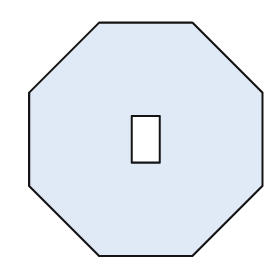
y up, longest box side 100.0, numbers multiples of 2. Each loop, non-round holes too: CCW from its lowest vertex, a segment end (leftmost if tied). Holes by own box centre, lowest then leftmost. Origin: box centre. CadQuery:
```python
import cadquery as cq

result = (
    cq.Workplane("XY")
    .moveTo(-20.0, -50.0)
    .lineTo(20.0, -50.0)
    .lineTo(50.0, -20.0)
    .lineTo(50.0, 20.0)
    .lineTo(20.0, 50.0)
    .lineTo(-20.0, 50.0)
    .lineTo(-50.0, 20.0)
    .lineTo(-50.0, -20.0)
    .close()
    .moveTo(-6.0, -10.0)
    .lineTo(6.0, -10.0)
    .lineTo(6.0, 10.0)
    .lineTo(-6.0, 10.0)
    .close()
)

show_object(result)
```